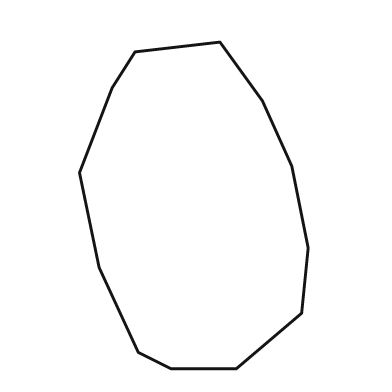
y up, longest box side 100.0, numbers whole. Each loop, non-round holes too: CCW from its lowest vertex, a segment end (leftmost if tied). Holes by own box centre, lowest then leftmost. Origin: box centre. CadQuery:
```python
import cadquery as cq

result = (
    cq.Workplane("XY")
    .moveTo(-7.0, -50.0)
    .lineTo(13.0, -50.0)
    .lineTo(33.0, -33.0)
    .lineTo(35.0, -13.0)
    .lineTo(30.0, 12.0)
    .lineTo(21.0, 32.0)
    .lineTo(8.0, 50.0)
    .lineTo(-18.0, 47.0)
    .lineTo(-25.0, 36.0)
    .lineTo(-35.0, 10.0)
    .lineTo(-29.0, -19.0)
    .lineTo(-17.0, -45.0)
    .close()
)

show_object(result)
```